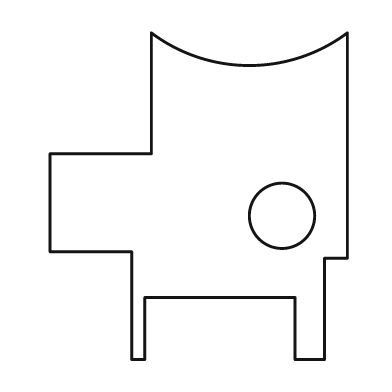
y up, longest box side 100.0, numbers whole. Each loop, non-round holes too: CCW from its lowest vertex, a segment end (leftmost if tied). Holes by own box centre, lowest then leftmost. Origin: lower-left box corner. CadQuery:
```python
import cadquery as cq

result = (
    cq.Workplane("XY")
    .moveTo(25.0, 0.0)
    .lineTo(29.0, 0.0)
    .lineTo(29.0, 19.0)
    .lineTo(75.0, 19.0)
    .lineTo(75.0, 0.0)
    .lineTo(84.0, 0.0)
    .lineTo(84.0, 31.0)
    .lineTo(91.0, 31.0)
    .lineTo(91.0, 100.0)
    .threePointArc((61.0, 90.0), (31.0, 100.0))
    .lineTo(31.0, 63.0)
    .lineTo(0.0, 63.0)
    .lineTo(0.0, 33.0)
    .lineTo(25.0, 33.0)
    .close()
    .moveTo(71.0, 44.0)
    .circle(10.0)
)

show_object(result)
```